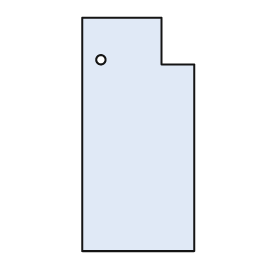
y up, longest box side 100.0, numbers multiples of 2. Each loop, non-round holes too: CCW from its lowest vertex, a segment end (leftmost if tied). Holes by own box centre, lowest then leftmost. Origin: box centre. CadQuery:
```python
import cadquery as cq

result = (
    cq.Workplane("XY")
    .moveTo(-24.0, -50.0)
    .lineTo(24.0, -50.0)
    .lineTo(24.0, 30.0)
    .lineTo(10.0, 30.0)
    .lineTo(10.0, 50.0)
    .lineTo(-24.0, 50.0)
    .close()
    .moveTo(-16.0, 32.0)
    .circle(2.0)
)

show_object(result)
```